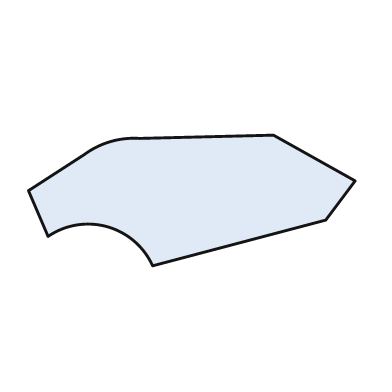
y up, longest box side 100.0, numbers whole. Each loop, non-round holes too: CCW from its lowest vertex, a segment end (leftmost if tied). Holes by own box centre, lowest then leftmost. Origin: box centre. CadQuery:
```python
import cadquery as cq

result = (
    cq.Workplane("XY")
    .moveTo(-12.0, -20.0)
    .lineTo(41.0, -6.0)
    .lineTo(50.0, 6.0)
    .lineTo(25.0, 20.0)
    .lineTo(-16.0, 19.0)
    .threePointArc((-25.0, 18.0), (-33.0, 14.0))
    .lineTo(-50.0, 3.0)
    .lineTo(-44.0, -11.0)
    .threePointArc((-26.0, -8.0), (-12.0, -20.0))
    .close()
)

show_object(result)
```